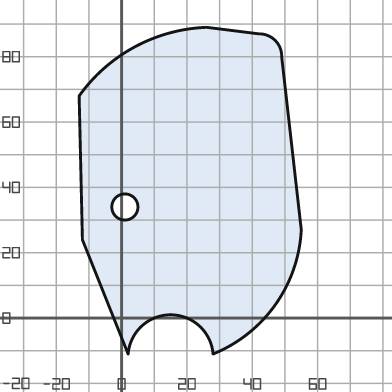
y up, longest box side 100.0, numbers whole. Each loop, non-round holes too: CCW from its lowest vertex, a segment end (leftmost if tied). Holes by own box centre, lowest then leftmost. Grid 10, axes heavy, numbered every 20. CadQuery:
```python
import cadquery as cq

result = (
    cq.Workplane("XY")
    .moveTo(2.0, -11.0)
    .threePointArc((15.0, 1.0), (28.0, -11.0))
    .threePointArc((47.0, 4.0), (55.0, 27.0))
    .lineTo(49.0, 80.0)
    .threePointArc((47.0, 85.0), (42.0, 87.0))
    .lineTo(26.0, 89.0)
    .threePointArc((4.0, 83.0), (-13.0, 68.0))
    .lineTo(-12.0, 24.0)
    .close()
    .moveTo(1.0, 34.0)
    .circle(4.0)
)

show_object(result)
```